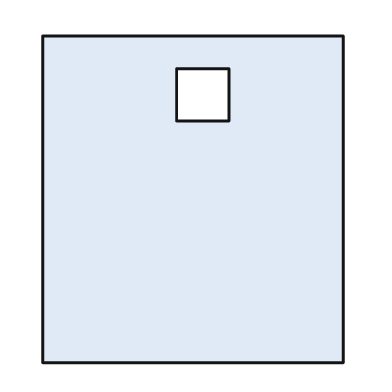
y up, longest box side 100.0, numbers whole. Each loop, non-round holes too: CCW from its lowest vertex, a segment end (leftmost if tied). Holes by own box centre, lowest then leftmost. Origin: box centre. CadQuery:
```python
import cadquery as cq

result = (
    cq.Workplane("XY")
    .moveTo(-46.0, -50.0)
    .lineTo(46.0, -50.0)
    .lineTo(46.0, 50.0)
    .lineTo(-46.0, 50.0)
    .close()
    .moveTo(-5.0, 24.0)
    .lineTo(11.0, 24.0)
    .lineTo(11.0, 40.0)
    .lineTo(-5.0, 40.0)
    .close()
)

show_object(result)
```